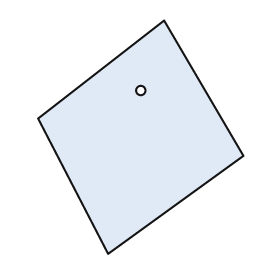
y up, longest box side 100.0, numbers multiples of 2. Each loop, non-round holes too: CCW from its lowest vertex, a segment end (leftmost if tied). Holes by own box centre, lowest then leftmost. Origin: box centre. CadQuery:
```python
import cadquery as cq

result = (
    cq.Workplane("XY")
    .moveTo(-14.0, -50.0)
    .lineTo(44.0, -8.0)
    .lineTo(10.0, 50.0)
    .lineTo(-44.0, 8.0)
    .close()
    .moveTo(0.0, 20.0)
    .circle(2.0)
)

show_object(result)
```